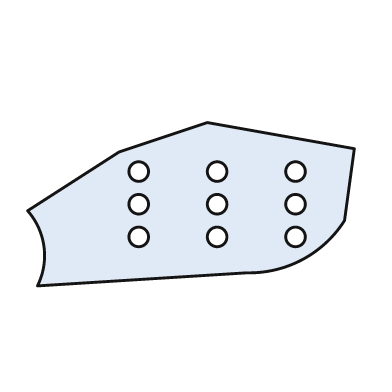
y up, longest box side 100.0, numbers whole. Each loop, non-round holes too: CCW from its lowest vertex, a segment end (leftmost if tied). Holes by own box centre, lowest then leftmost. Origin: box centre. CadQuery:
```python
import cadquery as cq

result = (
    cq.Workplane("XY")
    .moveTo(-47.0, -25.0)
    .lineTo(17.0, -21.0)
    .threePointArc((34.0, -17.0), (47.0, -5.0))
    .lineTo(50.0, 17.0)
    .lineTo(5.0, 25.0)
    .lineTo(-22.0, 16.0)
    .lineTo(-50.0, -2.0)
    .threePointArc((-45.0, -13.0), (-47.0, -25.0))
    .close()
    .moveTo(-16.0, -10.0)
    .circle(3.0)
    .moveTo(8.0, -10.0)
    .circle(3.0)
    .moveTo(32.0, -10.0)
    .circle(3.0)
    .moveTo(-16.0, 0.0)
    .circle(3.0)
    .moveTo(8.0, 0.0)
    .circle(3.0)
    .moveTo(32.0, 0.0)
    .circle(3.0)
    .moveTo(-16.0, 10.0)
    .circle(3.0)
    .moveTo(8.0, 10.0)
    .circle(3.0)
    .moveTo(32.0, 10.0)
    .circle(3.0)
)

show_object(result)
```